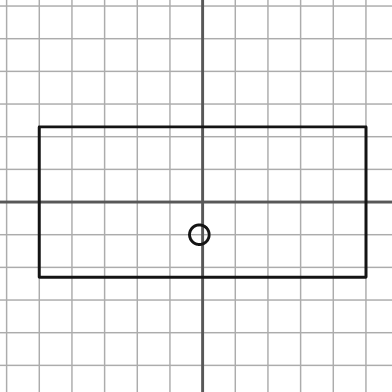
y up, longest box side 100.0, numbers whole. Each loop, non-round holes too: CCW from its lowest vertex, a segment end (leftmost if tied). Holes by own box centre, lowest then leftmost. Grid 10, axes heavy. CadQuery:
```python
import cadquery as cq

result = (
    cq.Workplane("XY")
    .moveTo(-50.0, -23.0)
    .lineTo(50.0, -23.0)
    .lineTo(50.0, 23.0)
    .lineTo(-50.0, 23.0)
    .close()
    .moveTo(-1.0, -10.0)
    .circle(3.0)
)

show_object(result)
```